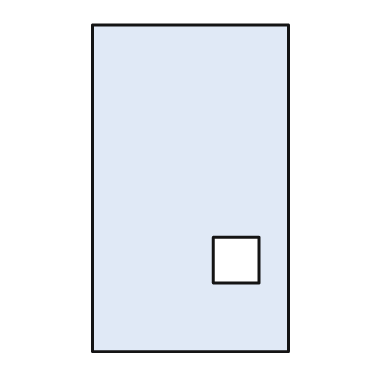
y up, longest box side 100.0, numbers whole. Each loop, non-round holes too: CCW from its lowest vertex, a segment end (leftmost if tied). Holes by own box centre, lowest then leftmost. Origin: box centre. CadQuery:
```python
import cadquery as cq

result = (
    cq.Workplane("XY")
    .moveTo(-30.0, -50.0)
    .lineTo(30.0, -50.0)
    .lineTo(30.0, 50.0)
    .lineTo(-30.0, 50.0)
    .close()
    .moveTo(7.0, -29.0)
    .lineTo(21.0, -29.0)
    .lineTo(21.0, -15.0)
    .lineTo(7.0, -15.0)
    .close()
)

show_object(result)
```